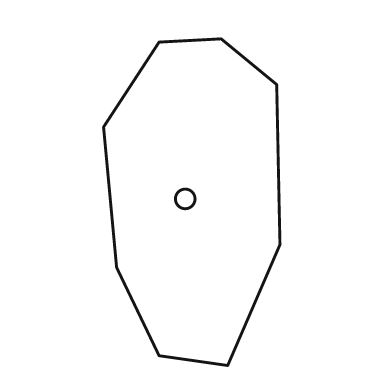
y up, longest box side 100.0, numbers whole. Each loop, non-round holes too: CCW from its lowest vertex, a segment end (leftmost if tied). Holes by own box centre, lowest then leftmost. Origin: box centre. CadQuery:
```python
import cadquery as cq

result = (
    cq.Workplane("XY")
    .moveTo(11.0, -50.0)
    .lineTo(27.0, -13.0)
    .lineTo(26.0, 36.0)
    .lineTo(9.0, 50.0)
    .lineTo(-10.0, 49.0)
    .lineTo(-27.0, 23.0)
    .lineTo(-23.0, -20.0)
    .lineTo(-10.0, -47.0)
    .close()
    .moveTo(-2.0, 1.0)
    .circle(3.0)
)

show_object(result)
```